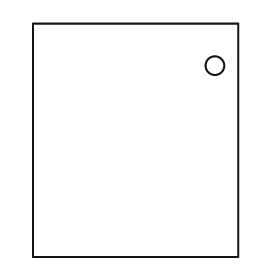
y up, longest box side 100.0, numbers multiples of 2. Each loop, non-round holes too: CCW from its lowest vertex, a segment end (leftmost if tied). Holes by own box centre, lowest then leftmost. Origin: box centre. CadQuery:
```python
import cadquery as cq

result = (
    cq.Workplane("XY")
    .moveTo(-44.0, -50.0)
    .lineTo(44.0, -50.0)
    .lineTo(44.0, 50.0)
    .lineTo(-44.0, 50.0)
    .close()
    .moveTo(34.0, 32.0)
    .circle(4.0)
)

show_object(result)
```